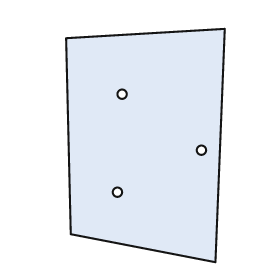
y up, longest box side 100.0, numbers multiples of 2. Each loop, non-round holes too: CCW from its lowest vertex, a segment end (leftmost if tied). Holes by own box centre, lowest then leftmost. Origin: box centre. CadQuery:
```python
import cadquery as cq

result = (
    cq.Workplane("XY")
    .moveTo(30.0, -50.0)
    .lineTo(34.0, 50.0)
    .lineTo(-34.0, 46.0)
    .lineTo(-32.0, -38.0)
    .close()
    .moveTo(-12.0, -20.0)
    .circle(2.0)
    .moveTo(24.0, -2.0)
    .circle(2.0)
    .moveTo(-10.0, 22.0)
    .circle(2.0)
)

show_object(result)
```